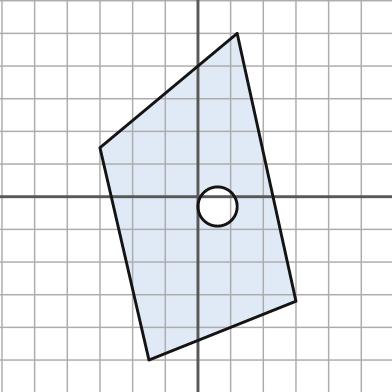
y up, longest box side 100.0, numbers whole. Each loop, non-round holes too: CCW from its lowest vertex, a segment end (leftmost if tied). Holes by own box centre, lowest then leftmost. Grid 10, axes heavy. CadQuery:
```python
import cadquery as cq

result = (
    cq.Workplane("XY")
    .moveTo(-15.0, -50.0)
    .lineTo(30.0, -32.0)
    .lineTo(12.0, 50.0)
    .lineTo(-30.0, 15.0)
    .close()
    .moveTo(6.0, -3.0)
    .circle(6.0)
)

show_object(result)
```